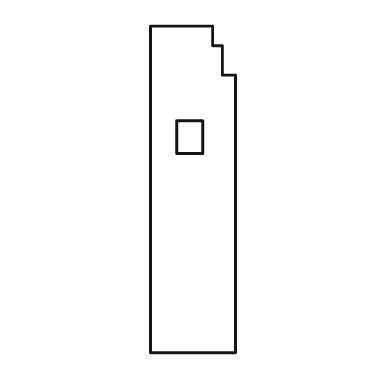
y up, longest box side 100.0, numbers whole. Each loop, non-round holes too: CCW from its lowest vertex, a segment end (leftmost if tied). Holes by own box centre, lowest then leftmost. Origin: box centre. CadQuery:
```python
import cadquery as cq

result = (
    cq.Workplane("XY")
    .moveTo(-13.0, -50.0)
    .lineTo(13.0, -50.0)
    .lineTo(13.0, 35.0)
    .lineTo(9.0, 35.0)
    .lineTo(9.0, 44.0)
    .lineTo(6.0, 44.0)
    .lineTo(6.0, 50.0)
    .lineTo(-13.0, 50.0)
    .close()
    .moveTo(-5.0, 11.0)
    .lineTo(3.0, 11.0)
    .lineTo(3.0, 21.0)
    .lineTo(-5.0, 21.0)
    .close()
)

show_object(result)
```